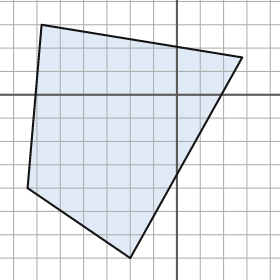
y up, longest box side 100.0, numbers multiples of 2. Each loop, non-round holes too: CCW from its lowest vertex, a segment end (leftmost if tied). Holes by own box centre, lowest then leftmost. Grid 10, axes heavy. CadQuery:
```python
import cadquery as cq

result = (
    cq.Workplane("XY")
    .moveTo(-20.0, -70.0)
    .lineTo(28.0, 16.0)
    .lineTo(-58.0, 30.0)
    .lineTo(-64.0, -40.0)
    .close()
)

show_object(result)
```